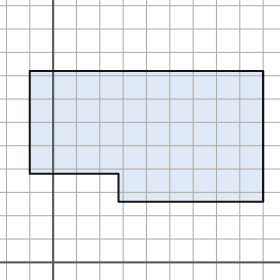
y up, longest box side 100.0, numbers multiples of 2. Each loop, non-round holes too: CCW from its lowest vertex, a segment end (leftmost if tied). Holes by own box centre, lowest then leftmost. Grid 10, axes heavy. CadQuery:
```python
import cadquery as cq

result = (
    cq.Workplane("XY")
    .moveTo(28.0, 26.0)
    .lineTo(90.0, 26.0)
    .lineTo(90.0, 82.0)
    .lineTo(-10.0, 82.0)
    .lineTo(-10.0, 38.0)
    .lineTo(28.0, 38.0)
    .close()
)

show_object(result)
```